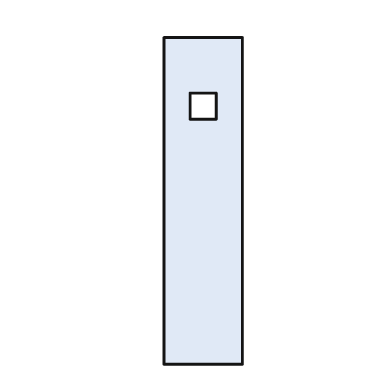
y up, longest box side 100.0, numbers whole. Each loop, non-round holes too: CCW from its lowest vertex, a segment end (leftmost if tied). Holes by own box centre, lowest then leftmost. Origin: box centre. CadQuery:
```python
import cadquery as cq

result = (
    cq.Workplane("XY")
    .moveTo(-12.0, -50.0)
    .lineTo(12.0, -50.0)
    .lineTo(12.0, 50.0)
    .lineTo(-12.0, 50.0)
    .close()
    .moveTo(-4.0, 25.0)
    .lineTo(4.0, 25.0)
    .lineTo(4.0, 33.0)
    .lineTo(-4.0, 33.0)
    .close()
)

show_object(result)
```